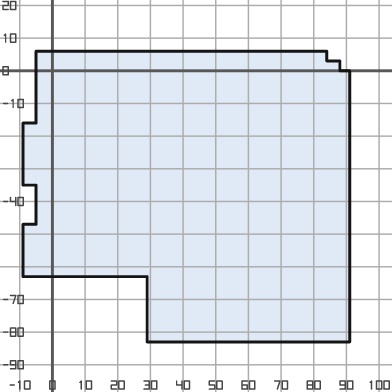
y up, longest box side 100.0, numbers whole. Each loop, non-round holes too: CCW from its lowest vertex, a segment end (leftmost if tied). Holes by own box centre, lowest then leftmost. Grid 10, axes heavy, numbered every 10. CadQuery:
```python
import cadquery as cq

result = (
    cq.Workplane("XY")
    .moveTo(29.0, -83.0)
    .lineTo(91.0, -83.0)
    .lineTo(91.0, 0.0)
    .lineTo(88.0, 0.0)
    .lineTo(88.0, 3.0)
    .lineTo(84.0, 3.0)
    .lineTo(84.0, 6.0)
    .lineTo(-5.0, 6.0)
    .lineTo(-5.0, -16.0)
    .lineTo(-9.0, -16.0)
    .lineTo(-9.0, -35.0)
    .lineTo(-5.0, -35.0)
    .lineTo(-5.0, -47.0)
    .lineTo(-9.0, -47.0)
    .lineTo(-9.0, -63.0)
    .lineTo(29.0, -63.0)
    .close()
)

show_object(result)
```